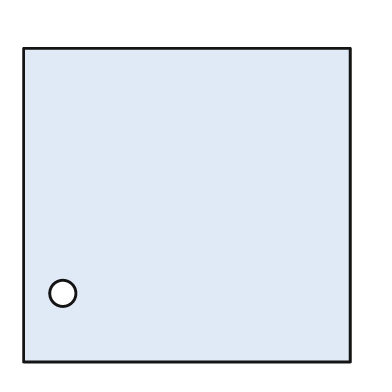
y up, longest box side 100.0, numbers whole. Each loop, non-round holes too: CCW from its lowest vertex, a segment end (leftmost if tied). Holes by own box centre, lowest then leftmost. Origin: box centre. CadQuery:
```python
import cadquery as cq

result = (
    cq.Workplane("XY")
    .moveTo(-50.0, -48.0)
    .lineTo(50.0, -48.0)
    .lineTo(50.0, 48.0)
    .lineTo(-50.0, 48.0)
    .close()
    .moveTo(-38.0, -27.0)
    .circle(4.0)
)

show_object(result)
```